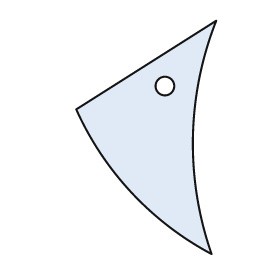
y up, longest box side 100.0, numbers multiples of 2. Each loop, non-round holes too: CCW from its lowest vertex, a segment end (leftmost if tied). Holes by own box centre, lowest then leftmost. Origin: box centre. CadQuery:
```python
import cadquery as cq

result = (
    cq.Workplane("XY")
    .moveTo(28.0, -50.0)
    .threePointArc((20.0, 0.0), (30.0, 50.0))
    .lineTo(-30.0, 12.0)
    .threePointArc((-6.0, -24.0), (28.0, -50.0))
    .close()
    .moveTo(8.0, 22.0)
    .circle(4.0)
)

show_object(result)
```